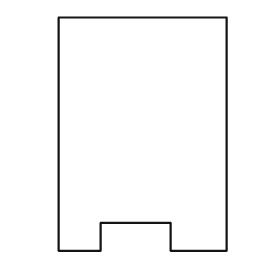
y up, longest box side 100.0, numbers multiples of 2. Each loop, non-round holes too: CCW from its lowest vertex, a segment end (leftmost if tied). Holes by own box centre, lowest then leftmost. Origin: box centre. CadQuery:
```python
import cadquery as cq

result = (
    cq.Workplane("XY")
    .moveTo(-36.0, -50.0)
    .lineTo(-18.0, -50.0)
    .lineTo(-18.0, -38.0)
    .lineTo(12.0, -38.0)
    .lineTo(12.0, -50.0)
    .lineTo(36.0, -50.0)
    .lineTo(36.0, 50.0)
    .lineTo(-36.0, 50.0)
    .close()
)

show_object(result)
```